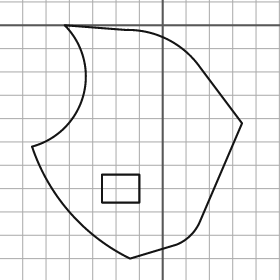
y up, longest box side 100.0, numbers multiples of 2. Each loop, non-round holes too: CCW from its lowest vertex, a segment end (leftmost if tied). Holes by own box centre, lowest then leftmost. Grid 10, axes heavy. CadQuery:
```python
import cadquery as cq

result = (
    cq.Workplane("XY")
    .moveTo(-14.0, -100.0)
    .lineTo(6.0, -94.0)
    .threePointArc((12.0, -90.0), (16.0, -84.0))
    .lineTo(34.0, -42.0)
    .lineTo(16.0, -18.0)
    .threePointArc((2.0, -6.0), (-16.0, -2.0))
    .lineTo(-42.0, 0.0)
    .threePointArc((-34.0, -30.0), (-56.0, -52.0))
    .threePointArc((-40.0, -80.0), (-14.0, -100.0))
    .close()
    .moveTo(-26.0, -76.0)
    .lineTo(-10.0, -76.0)
    .lineTo(-10.0, -64.0)
    .lineTo(-26.0, -64.0)
    .close()
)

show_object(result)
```